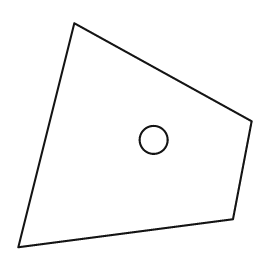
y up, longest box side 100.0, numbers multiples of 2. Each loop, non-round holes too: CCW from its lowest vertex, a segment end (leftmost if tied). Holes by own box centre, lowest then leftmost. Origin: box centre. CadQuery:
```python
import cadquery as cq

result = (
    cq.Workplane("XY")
    .moveTo(-50.0, -48.0)
    .lineTo(42.0, -36.0)
    .lineTo(50.0, 6.0)
    .lineTo(-26.0, 48.0)
    .close()
    .moveTo(8.0, -2.0)
    .circle(6.0)
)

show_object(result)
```